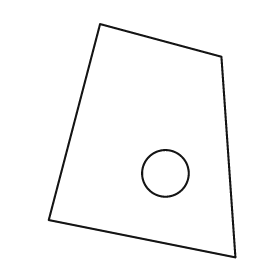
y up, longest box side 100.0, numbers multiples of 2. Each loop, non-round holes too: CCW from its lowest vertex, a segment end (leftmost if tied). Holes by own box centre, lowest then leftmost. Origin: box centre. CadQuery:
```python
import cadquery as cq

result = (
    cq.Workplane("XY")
    .moveTo(40.0, -50.0)
    .lineTo(34.0, 36.0)
    .lineTo(-18.0, 50.0)
    .lineTo(-40.0, -34.0)
    .close()
    .moveTo(10.0, -14.0)
    .circle(10.0)
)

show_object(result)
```